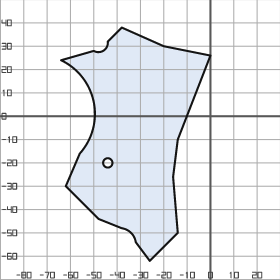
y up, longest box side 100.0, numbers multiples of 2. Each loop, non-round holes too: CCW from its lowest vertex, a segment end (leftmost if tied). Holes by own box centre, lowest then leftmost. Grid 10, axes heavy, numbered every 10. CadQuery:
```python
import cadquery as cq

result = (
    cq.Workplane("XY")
    .moveTo(-26.0, -62.0)
    .lineTo(-14.0, -50.0)
    .lineTo(-16.0, -26.0)
    .lineTo(-14.0, -10.0)
    .lineTo(0.0, 26.0)
    .lineTo(-20.0, 30.0)
    .lineTo(-38.0, 38.0)
    .lineTo(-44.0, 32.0)
    .threePointArc((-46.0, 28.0), (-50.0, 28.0))
    .lineTo(-64.0, 24.0)
    .threePointArc((-50.0, 6.0), (-56.0, -16.0))
    .lineTo(-62.0, -30.0)
    .lineTo(-48.0, -44.0)
    .lineTo(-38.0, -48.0)
    .threePointArc((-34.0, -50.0), (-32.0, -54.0))
    .close()
    .moveTo(-44.0, -20.0)
    .circle(2.0)
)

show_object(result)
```